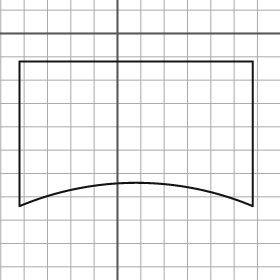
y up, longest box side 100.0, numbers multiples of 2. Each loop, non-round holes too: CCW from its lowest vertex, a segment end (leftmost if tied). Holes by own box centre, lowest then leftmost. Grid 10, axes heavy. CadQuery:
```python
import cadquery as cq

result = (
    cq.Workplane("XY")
    .moveTo(-42.0, -74.0)
    .threePointArc((8.0, -64.0), (58.0, -74.0))
    .lineTo(58.0, -12.0)
    .lineTo(-42.0, -12.0)
    .close()
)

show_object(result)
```